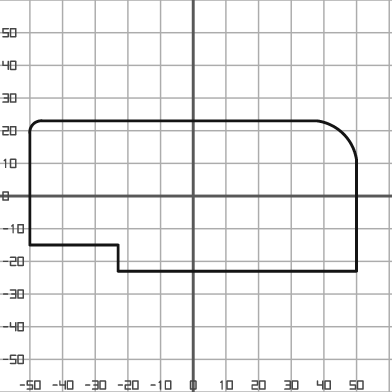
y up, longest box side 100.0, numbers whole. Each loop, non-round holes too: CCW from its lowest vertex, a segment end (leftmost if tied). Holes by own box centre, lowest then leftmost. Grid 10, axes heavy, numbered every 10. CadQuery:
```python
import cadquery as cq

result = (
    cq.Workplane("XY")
    .moveTo(-23.0, -23.0)
    .lineTo(50.0, -23.0)
    .lineTo(50.0, 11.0)
    .threePointArc((46.0, 19.0), (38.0, 23.0))
    .lineTo(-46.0, 23.0)
    .threePointArc((-49.0, 22.0), (-50.0, 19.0))
    .lineTo(-50.0, -15.0)
    .lineTo(-23.0, -15.0)
    .close()
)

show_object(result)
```